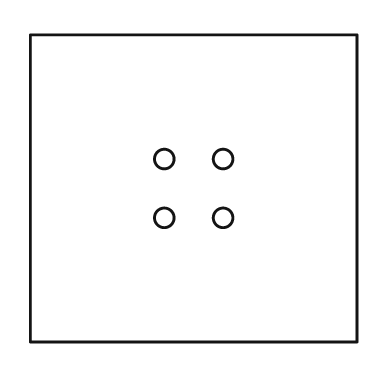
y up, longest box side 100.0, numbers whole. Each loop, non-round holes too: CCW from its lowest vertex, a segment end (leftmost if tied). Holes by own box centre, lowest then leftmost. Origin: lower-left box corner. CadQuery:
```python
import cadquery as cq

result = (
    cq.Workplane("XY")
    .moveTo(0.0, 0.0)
    .lineTo(100.0, 0.0)
    .lineTo(100.0, 94.0)
    .lineTo(0.0, 94.0)
    .close()
    .moveTo(41.0, 38.0)
    .circle(3.0)
    .moveTo(59.0, 38.0)
    .circle(3.0)
    .moveTo(41.0, 56.0)
    .circle(3.0)
    .moveTo(59.0, 56.0)
    .circle(3.0)
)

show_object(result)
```